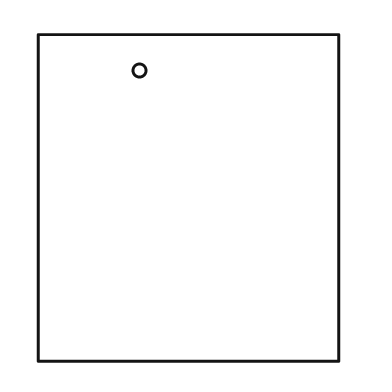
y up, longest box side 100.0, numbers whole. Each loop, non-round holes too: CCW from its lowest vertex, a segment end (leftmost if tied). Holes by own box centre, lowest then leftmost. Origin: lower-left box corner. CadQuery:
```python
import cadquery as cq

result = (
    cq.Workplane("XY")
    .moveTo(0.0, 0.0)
    .lineTo(92.0, 0.0)
    .lineTo(92.0, 100.0)
    .lineTo(0.0, 100.0)
    .close()
    .moveTo(31.0, 89.0)
    .circle(2.0)
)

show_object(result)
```